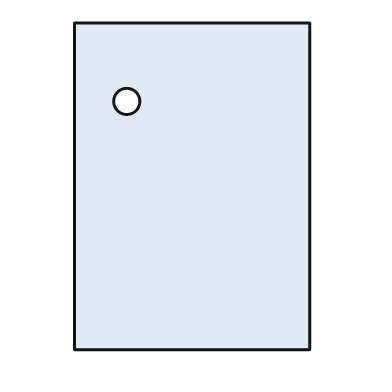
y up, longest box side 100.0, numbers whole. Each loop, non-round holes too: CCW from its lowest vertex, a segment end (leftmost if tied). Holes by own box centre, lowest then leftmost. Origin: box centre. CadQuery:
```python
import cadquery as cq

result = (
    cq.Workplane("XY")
    .moveTo(-36.0, -50.0)
    .lineTo(36.0, -50.0)
    .lineTo(36.0, 50.0)
    .lineTo(-36.0, 50.0)
    .close()
    .moveTo(-20.0, 26.0)
    .circle(4.0)
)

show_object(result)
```